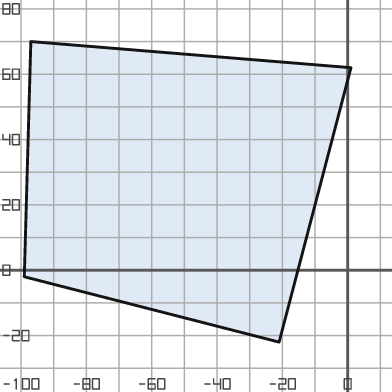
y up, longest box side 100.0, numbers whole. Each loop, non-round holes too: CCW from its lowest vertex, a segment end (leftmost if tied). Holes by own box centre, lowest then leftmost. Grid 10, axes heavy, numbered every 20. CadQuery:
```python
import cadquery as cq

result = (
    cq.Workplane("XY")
    .moveTo(-21.0, -22.0)
    .lineTo(1.0, 62.0)
    .lineTo(-97.0, 70.0)
    .lineTo(-99.0, -2.0)
    .close()
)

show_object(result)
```